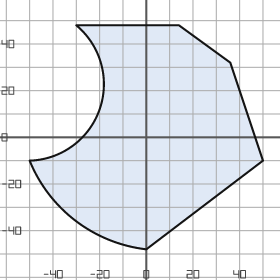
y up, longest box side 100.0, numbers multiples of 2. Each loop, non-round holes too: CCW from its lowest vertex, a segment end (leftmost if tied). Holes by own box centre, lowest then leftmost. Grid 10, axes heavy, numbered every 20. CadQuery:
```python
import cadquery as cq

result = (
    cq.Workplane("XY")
    .moveTo(0.0, -48.0)
    .lineTo(50.0, -10.0)
    .lineTo(36.0, 32.0)
    .lineTo(14.0, 48.0)
    .lineTo(-30.0, 48.0)
    .threePointArc((-20.0, 12.0), (-50.0, -10.0))
    .threePointArc((-30.0, -36.0), (0.0, -48.0))
    .close()
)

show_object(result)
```